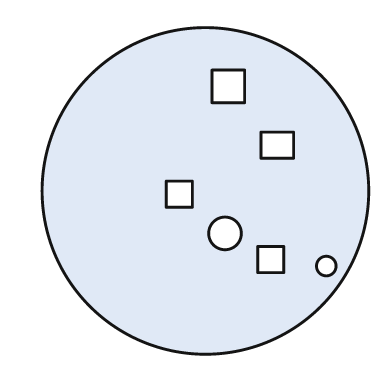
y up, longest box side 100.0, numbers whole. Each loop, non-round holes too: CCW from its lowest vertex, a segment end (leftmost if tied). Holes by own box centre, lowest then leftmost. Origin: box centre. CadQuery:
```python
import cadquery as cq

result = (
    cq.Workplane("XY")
    .moveTo(0.0, 0.0)
    .circle(50.0)
    .moveTo(37.0, -23.0)
    .circle(3.0)
    .moveTo(16.0, -25.0)
    .lineTo(24.0, -25.0)
    .lineTo(24.0, -17.0)
    .lineTo(16.0, -17.0)
    .close()
    .moveTo(6.0, -13.0)
    .circle(5.0)
    .moveTo(-12.0, -5.0)
    .lineTo(-4.0, -5.0)
    .lineTo(-4.0, 3.0)
    .lineTo(-12.0, 3.0)
    .close()
    .moveTo(17.0, 10.0)
    .lineTo(27.0, 10.0)
    .lineTo(27.0, 18.0)
    .lineTo(17.0, 18.0)
    .close()
    .moveTo(2.0, 27.0)
    .lineTo(12.0, 27.0)
    .lineTo(12.0, 37.0)
    .lineTo(2.0, 37.0)
    .close()
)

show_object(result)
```